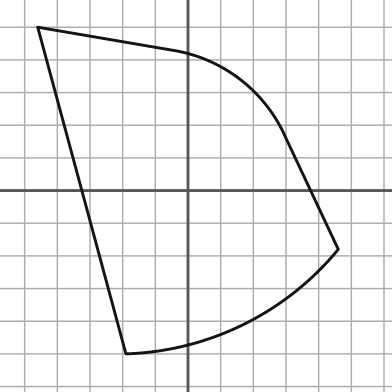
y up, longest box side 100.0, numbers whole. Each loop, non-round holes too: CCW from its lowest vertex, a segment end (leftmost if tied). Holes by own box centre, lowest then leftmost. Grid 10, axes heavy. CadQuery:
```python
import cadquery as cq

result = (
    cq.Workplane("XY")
    .moveTo(-19.0, -50.0)
    .threePointArc((17.0, -41.0), (46.0, -18.0))
    .lineTo(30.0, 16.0)
    .threePointArc((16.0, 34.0), (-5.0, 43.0))
    .lineTo(-46.0, 50.0)
    .close()
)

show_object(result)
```